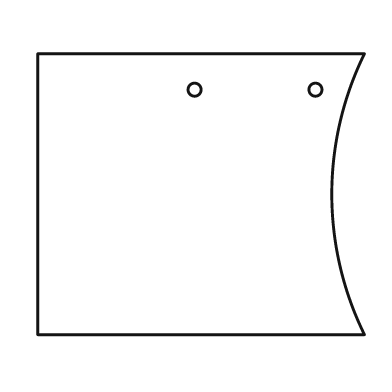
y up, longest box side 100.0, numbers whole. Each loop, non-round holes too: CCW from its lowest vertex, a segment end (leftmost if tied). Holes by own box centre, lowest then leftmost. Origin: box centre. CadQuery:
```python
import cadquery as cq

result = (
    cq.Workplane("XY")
    .moveTo(-50.0, -43.0)
    .lineTo(50.0, -43.0)
    .threePointArc((40.0, 0.0), (50.0, 43.0))
    .lineTo(-50.0, 43.0)
    .close()
    .moveTo(-2.0, 32.0)
    .circle(2.0)
    .moveTo(35.0, 32.0)
    .circle(2.0)
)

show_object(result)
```